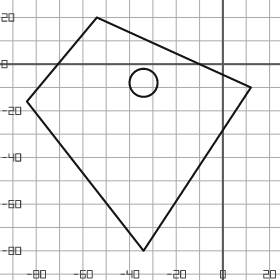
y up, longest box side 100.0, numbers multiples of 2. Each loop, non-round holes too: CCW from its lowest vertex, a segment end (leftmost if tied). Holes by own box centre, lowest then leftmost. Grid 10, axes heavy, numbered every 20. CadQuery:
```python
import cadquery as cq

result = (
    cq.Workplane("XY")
    .moveTo(-34.0, -80.0)
    .lineTo(12.0, -10.0)
    .lineTo(-54.0, 20.0)
    .lineTo(-84.0, -16.0)
    .close()
    .moveTo(-34.0, -8.0)
    .circle(6.0)
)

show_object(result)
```